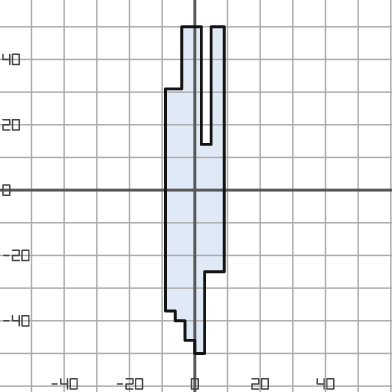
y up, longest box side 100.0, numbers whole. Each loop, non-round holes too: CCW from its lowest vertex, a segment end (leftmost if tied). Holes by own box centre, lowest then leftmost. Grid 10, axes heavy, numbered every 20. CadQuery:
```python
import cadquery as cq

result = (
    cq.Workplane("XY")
    .moveTo(0.0, -50.0)
    .lineTo(3.0, -50.0)
    .lineTo(3.0, -25.0)
    .lineTo(9.0, -25.0)
    .lineTo(9.0, 50.0)
    .lineTo(5.0, 50.0)
    .lineTo(5.0, 14.0)
    .lineTo(2.0, 14.0)
    .lineTo(2.0, 50.0)
    .lineTo(-4.0, 50.0)
    .lineTo(-4.0, 31.0)
    .lineTo(-9.0, 31.0)
    .lineTo(-9.0, -37.0)
    .lineTo(-6.0, -37.0)
    .lineTo(-6.0, -40.0)
    .lineTo(-3.0, -40.0)
    .lineTo(-3.0, -46.0)
    .lineTo(0.0, -46.0)
    .close()
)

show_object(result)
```